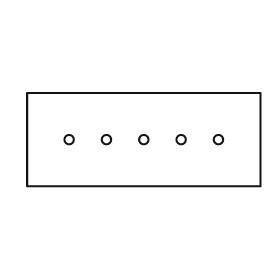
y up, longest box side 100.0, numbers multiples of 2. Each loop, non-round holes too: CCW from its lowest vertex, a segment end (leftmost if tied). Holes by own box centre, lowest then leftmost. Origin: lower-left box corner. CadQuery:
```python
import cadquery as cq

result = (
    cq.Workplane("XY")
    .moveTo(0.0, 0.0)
    .lineTo(100.0, 0.0)
    .lineTo(100.0, 40.0)
    .lineTo(0.0, 40.0)
    .close()
    .moveTo(18.0, 20.0)
    .circle(2.0)
    .moveTo(34.0, 20.0)
    .circle(2.0)
    .moveTo(50.0, 20.0)
    .circle(2.0)
    .moveTo(66.0, 20.0)
    .circle(2.0)
    .moveTo(82.0, 20.0)
    .circle(2.0)
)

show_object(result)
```